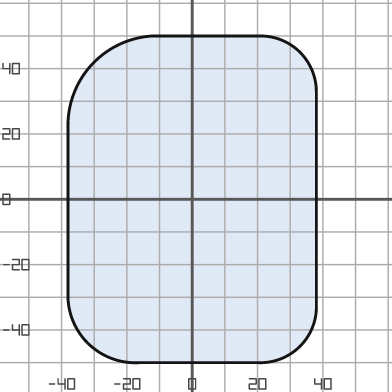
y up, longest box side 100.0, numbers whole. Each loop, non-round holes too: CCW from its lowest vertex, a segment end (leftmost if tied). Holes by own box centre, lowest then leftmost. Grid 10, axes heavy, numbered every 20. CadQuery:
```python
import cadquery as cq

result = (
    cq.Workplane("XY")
    .moveTo(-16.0, -50.0)
    .lineTo(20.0, -50.0)
    .threePointArc((33.0, -45.0), (38.0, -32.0))
    .lineTo(38.0, 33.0)
    .threePointArc((33.0, 45.0), (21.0, 50.0))
    .lineTo(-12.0, 50.0)
    .threePointArc((-30.0, 42.0), (-38.0, 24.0))
    .lineTo(-38.0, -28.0)
    .threePointArc((-32.0, -44.0), (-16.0, -50.0))
    .close()
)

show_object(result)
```